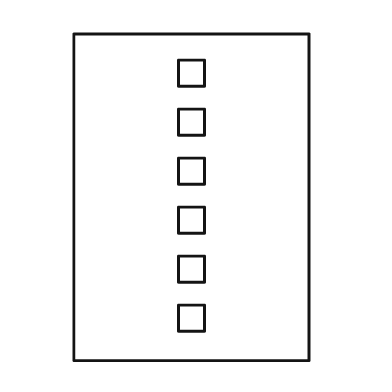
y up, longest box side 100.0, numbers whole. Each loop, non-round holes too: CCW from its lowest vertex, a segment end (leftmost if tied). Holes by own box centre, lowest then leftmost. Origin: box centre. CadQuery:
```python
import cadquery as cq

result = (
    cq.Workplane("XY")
    .moveTo(-36.0, -50.0)
    .lineTo(36.0, -50.0)
    .lineTo(36.0, 50.0)
    .lineTo(-36.0, 50.0)
    .close()
    .moveTo(-4.0, -41.0)
    .lineTo(4.0, -41.0)
    .lineTo(4.0, -33.0)
    .lineTo(-4.0, -33.0)
    .close()
    .moveTo(-4.0, -26.0)
    .lineTo(4.0, -26.0)
    .lineTo(4.0, -18.0)
    .lineTo(-4.0, -18.0)
    .close()
    .moveTo(-4.0, -11.0)
    .lineTo(4.0, -11.0)
    .lineTo(4.0, -3.0)
    .lineTo(-4.0, -3.0)
    .close()
    .moveTo(-4.0, 4.0)
    .lineTo(4.0, 4.0)
    .lineTo(4.0, 12.0)
    .lineTo(-4.0, 12.0)
    .close()
    .moveTo(-4.0, 19.0)
    .lineTo(4.0, 19.0)
    .lineTo(4.0, 27.0)
    .lineTo(-4.0, 27.0)
    .close()
    .moveTo(-4.0, 34.0)
    .lineTo(4.0, 34.0)
    .lineTo(4.0, 42.0)
    .lineTo(-4.0, 42.0)
    .close()
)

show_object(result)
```